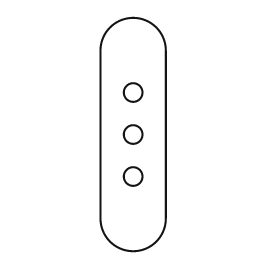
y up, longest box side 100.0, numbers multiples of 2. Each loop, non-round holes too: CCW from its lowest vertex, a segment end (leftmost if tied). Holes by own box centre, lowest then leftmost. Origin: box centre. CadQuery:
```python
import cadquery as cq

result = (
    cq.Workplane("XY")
    .moveTo(-14.0, -36.0)
    .threePointArc((0.0, -50.0), (14.0, -36.0))
    .lineTo(14.0, 36.0)
    .threePointArc((0.0, 50.0), (-14.0, 36.0))
    .close()
    .moveTo(0.0, -18.0)
    .circle(4.0)
    .moveTo(0.0, 0.0)
    .circle(4.0)
    .moveTo(0.0, 18.0)
    .circle(4.0)
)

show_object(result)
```